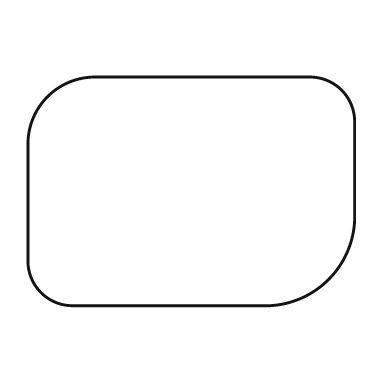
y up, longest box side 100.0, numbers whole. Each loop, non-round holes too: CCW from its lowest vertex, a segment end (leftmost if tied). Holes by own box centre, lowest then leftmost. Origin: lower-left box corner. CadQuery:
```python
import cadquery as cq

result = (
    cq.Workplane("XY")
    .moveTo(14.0, 0.0)
    .lineTo(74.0, 0.0)
    .threePointArc((92.0, 8.0), (100.0, 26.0))
    .lineTo(100.0, 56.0)
    .threePointArc((96.0, 66.0), (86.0, 70.0))
    .lineTo(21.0, 70.0)
    .threePointArc((6.0, 64.0), (0.0, 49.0))
    .lineTo(0.0, 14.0)
    .threePointArc((4.0, 4.0), (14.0, 0.0))
    .close()
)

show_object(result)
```